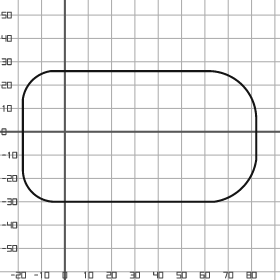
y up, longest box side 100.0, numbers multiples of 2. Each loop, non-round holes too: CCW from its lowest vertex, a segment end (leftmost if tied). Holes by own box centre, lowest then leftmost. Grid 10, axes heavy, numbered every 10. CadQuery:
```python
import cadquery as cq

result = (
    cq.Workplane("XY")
    .moveTo(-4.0, -30.0)
    .lineTo(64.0, -30.0)
    .threePointArc((76.0, -24.0), (82.0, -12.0))
    .lineTo(82.0, 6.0)
    .threePointArc((76.0, 20.0), (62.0, 26.0))
    .lineTo(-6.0, 26.0)
    .threePointArc((-14.0, 22.0), (-18.0, 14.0))
    .lineTo(-18.0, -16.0)
    .threePointArc((-14.0, -26.0), (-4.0, -30.0))
    .close()
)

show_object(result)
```